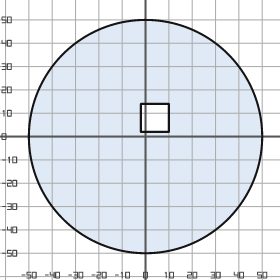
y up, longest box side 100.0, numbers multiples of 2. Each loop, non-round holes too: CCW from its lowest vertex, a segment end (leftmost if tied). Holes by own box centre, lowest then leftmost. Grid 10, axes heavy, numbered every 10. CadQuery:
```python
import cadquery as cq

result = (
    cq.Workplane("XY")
    .moveTo(0.0, 0.0)
    .circle(50.0)
    .moveTo(-2.0, 2.0)
    .lineTo(10.0, 2.0)
    .lineTo(10.0, 14.0)
    .lineTo(-2.0, 14.0)
    .close()
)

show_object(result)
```